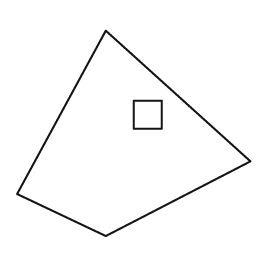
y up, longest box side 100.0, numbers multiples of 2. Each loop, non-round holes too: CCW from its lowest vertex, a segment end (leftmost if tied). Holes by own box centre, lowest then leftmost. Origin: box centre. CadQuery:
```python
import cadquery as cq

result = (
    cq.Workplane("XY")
    .moveTo(-12.0, -44.0)
    .lineTo(50.0, -12.0)
    .lineTo(-12.0, 44.0)
    .lineTo(-50.0, -26.0)
    .close()
    .moveTo(0.0, 2.0)
    .lineTo(12.0, 2.0)
    .lineTo(12.0, 14.0)
    .lineTo(0.0, 14.0)
    .close()
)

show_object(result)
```